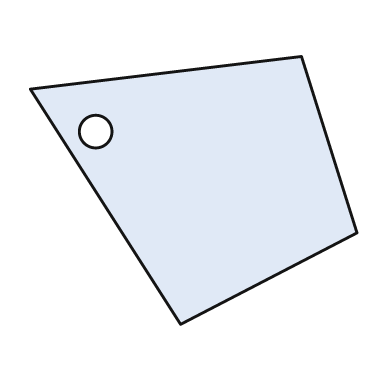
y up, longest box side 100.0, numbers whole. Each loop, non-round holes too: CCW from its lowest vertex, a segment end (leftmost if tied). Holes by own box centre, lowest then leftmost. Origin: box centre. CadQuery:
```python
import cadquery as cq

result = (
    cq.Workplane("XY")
    .moveTo(-4.0, -41.0)
    .lineTo(50.0, -13.0)
    .lineTo(33.0, 41.0)
    .lineTo(-50.0, 31.0)
    .close()
    .moveTo(-30.0, 18.0)
    .circle(5.0)
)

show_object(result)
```